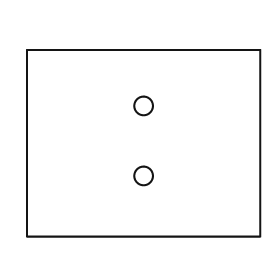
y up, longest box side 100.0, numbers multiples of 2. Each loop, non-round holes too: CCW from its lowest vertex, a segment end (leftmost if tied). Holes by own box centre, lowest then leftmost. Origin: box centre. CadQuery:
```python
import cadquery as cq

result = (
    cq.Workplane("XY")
    .moveTo(-50.0, -40.0)
    .lineTo(50.0, -40.0)
    .lineTo(50.0, 40.0)
    .lineTo(-50.0, 40.0)
    .close()
    .moveTo(0.0, -14.0)
    .circle(4.0)
    .moveTo(0.0, 16.0)
    .circle(4.0)
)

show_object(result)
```